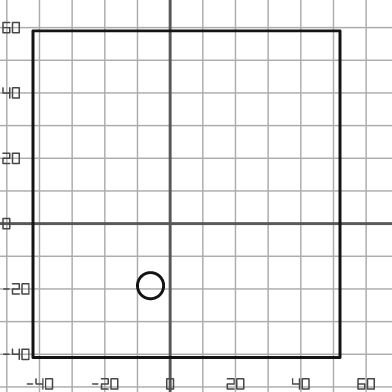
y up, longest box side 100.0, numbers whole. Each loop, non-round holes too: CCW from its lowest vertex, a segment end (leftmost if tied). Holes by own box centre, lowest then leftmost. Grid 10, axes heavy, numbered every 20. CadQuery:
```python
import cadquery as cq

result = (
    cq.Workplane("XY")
    .moveTo(-42.0, -41.0)
    .lineTo(52.0, -41.0)
    .lineTo(52.0, 59.0)
    .lineTo(-42.0, 59.0)
    .close()
    .moveTo(-6.0, -19.0)
    .circle(4.0)
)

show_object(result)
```